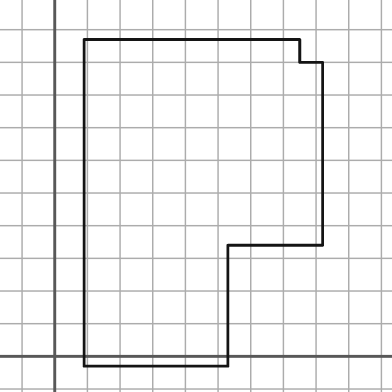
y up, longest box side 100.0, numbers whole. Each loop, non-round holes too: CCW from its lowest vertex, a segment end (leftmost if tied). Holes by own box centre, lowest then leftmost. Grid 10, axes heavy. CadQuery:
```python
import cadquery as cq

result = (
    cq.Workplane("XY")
    .moveTo(9.0, -3.0)
    .lineTo(53.0, -3.0)
    .lineTo(53.0, 34.0)
    .lineTo(82.0, 34.0)
    .lineTo(82.0, 90.0)
    .lineTo(75.0, 90.0)
    .lineTo(75.0, 97.0)
    .lineTo(9.0, 97.0)
    .close()
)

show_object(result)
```